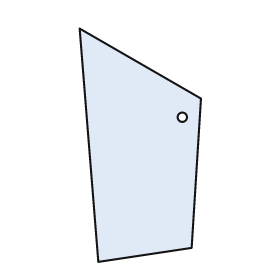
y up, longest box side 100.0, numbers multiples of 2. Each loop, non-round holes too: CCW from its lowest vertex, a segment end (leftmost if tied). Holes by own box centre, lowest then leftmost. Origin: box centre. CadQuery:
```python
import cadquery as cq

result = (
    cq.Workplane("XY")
    .moveTo(-18.0, -50.0)
    .lineTo(22.0, -44.0)
    .lineTo(26.0, 20.0)
    .lineTo(-26.0, 50.0)
    .close()
    .moveTo(18.0, 12.0)
    .circle(2.0)
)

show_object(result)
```